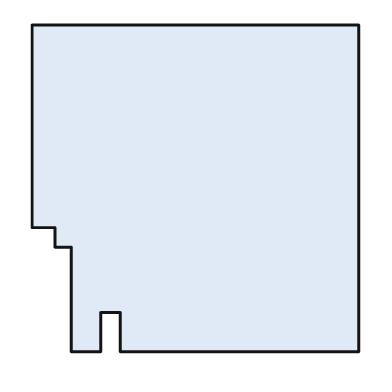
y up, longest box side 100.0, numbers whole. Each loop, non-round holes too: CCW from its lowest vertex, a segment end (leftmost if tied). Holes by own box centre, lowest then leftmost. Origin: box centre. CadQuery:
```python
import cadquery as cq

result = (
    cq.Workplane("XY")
    .moveTo(-38.0, -50.0)
    .lineTo(-29.0, -50.0)
    .lineTo(-29.0, -38.0)
    .lineTo(-23.0, -38.0)
    .lineTo(-23.0, -50.0)
    .lineTo(50.0, -50.0)
    .lineTo(50.0, 50.0)
    .lineTo(-50.0, 50.0)
    .lineTo(-50.0, -12.0)
    .lineTo(-43.0, -12.0)
    .lineTo(-43.0, -18.0)
    .lineTo(-38.0, -18.0)
    .close()
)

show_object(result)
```